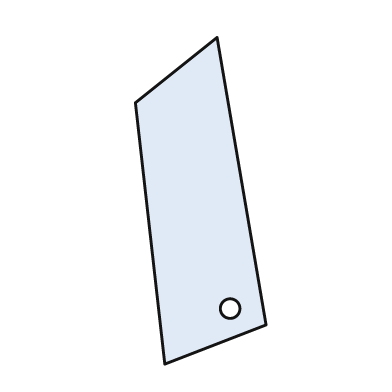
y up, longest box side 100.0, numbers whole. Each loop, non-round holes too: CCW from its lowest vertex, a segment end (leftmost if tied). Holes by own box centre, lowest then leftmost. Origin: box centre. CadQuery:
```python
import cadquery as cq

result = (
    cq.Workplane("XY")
    .moveTo(-11.0, -50.0)
    .lineTo(20.0, -38.0)
    .lineTo(5.0, 50.0)
    .lineTo(-20.0, 30.0)
    .close()
    .moveTo(9.0, -33.0)
    .circle(3.0)
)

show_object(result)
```